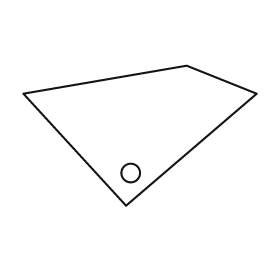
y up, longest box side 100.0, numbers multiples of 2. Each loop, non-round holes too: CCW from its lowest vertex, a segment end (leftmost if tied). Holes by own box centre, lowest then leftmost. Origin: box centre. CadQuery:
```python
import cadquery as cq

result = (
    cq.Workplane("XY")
    .moveTo(-6.0, -30.0)
    .lineTo(50.0, 18.0)
    .lineTo(20.0, 30.0)
    .lineTo(-50.0, 18.0)
    .close()
    .moveTo(-4.0, -16.0)
    .circle(4.0)
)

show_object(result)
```